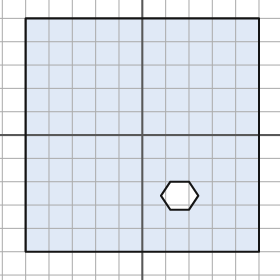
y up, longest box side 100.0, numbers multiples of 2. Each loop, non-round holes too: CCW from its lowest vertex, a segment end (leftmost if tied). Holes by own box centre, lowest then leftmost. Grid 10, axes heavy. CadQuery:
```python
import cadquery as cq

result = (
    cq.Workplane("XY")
    .moveTo(-50.0, -50.0)
    .lineTo(50.0, -50.0)
    .lineTo(50.0, 50.0)
    .lineTo(-50.0, 50.0)
    .close()
    .moveTo(12.0, -32.0)
    .lineTo(20.0, -32.0)
    .lineTo(24.0, -26.0)
    .lineTo(20.0, -20.0)
    .lineTo(12.0, -20.0)
    .lineTo(8.0, -26.0)
    .close()
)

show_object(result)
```